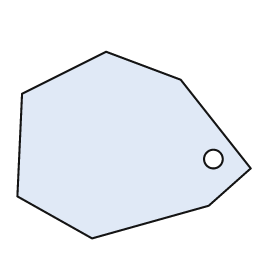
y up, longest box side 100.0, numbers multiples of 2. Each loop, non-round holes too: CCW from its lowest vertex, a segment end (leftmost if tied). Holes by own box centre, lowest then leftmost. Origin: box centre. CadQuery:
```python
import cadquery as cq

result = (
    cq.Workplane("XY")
    .moveTo(-18.0, -40.0)
    .lineTo(32.0, -26.0)
    .lineTo(50.0, -10.0)
    .lineTo(20.0, 28.0)
    .lineTo(-12.0, 40.0)
    .lineTo(-48.0, 22.0)
    .lineTo(-50.0, -22.0)
    .close()
    .moveTo(34.0, -6.0)
    .circle(4.0)
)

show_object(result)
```